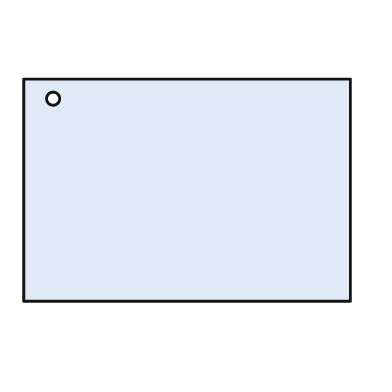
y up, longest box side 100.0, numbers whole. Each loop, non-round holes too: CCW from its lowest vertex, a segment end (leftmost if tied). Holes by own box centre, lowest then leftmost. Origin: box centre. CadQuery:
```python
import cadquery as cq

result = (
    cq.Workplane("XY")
    .moveTo(-50.0, -34.0)
    .lineTo(50.0, -34.0)
    .lineTo(50.0, 34.0)
    .lineTo(-50.0, 34.0)
    .close()
    .moveTo(-41.0, 28.0)
    .circle(2.0)
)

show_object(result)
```